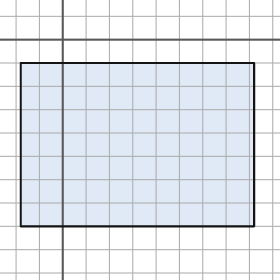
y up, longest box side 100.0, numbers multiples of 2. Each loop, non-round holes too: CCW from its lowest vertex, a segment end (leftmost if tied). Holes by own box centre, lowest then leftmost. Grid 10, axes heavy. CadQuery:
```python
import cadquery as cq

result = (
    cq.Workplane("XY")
    .moveTo(-18.0, -80.0)
    .lineTo(82.0, -80.0)
    .lineTo(82.0, -10.0)
    .lineTo(-18.0, -10.0)
    .close()
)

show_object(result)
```